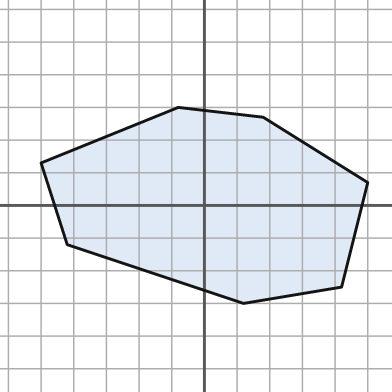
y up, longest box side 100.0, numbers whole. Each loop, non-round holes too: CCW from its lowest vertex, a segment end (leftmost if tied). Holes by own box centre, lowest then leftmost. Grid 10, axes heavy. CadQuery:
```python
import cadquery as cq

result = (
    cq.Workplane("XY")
    .moveTo(12.0, -30.0)
    .lineTo(42.0, -25.0)
    .lineTo(50.0, 7.0)
    .lineTo(18.0, 27.0)
    .lineTo(-8.0, 30.0)
    .lineTo(-50.0, 13.0)
    .lineTo(-42.0, -12.0)
    .close()
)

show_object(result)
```